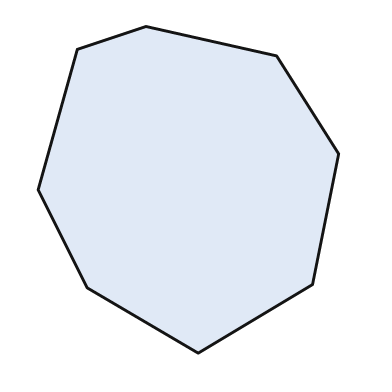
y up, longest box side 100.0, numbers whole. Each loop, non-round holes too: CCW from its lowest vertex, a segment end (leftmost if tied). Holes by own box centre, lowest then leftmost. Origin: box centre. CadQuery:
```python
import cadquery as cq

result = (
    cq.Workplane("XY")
    .moveTo(3.0, -50.0)
    .lineTo(38.0, -29.0)
    .lineTo(46.0, 11.0)
    .lineTo(27.0, 41.0)
    .lineTo(-13.0, 50.0)
    .lineTo(-34.0, 43.0)
    .lineTo(-46.0, 0.0)
    .lineTo(-31.0, -30.0)
    .close()
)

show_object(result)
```